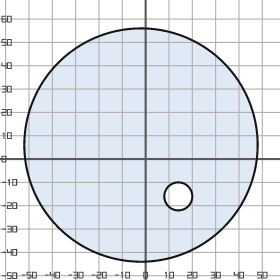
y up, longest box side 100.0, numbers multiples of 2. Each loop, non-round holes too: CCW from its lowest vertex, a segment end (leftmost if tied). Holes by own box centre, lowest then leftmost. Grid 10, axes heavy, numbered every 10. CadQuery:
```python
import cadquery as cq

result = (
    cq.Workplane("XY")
    .moveTo(-2.0, 6.0)
    .circle(50.0)
    .moveTo(14.0, -16.0)
    .circle(6.0)
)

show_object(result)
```